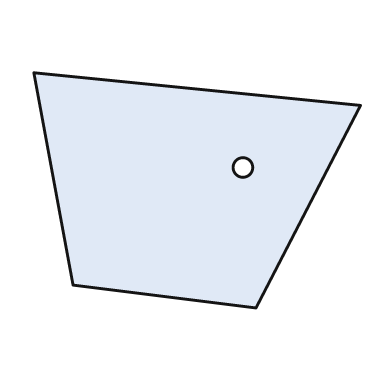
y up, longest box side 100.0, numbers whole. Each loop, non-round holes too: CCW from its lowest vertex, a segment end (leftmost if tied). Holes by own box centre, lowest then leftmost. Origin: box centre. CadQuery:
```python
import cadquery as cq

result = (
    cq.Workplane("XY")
    .moveTo(18.0, -36.0)
    .lineTo(50.0, 26.0)
    .lineTo(-50.0, 36.0)
    .lineTo(-38.0, -29.0)
    .close()
    .moveTo(14.0, 7.0)
    .circle(3.0)
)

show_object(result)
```